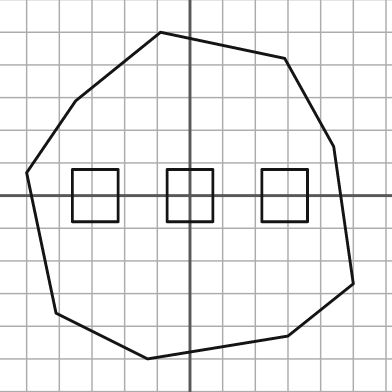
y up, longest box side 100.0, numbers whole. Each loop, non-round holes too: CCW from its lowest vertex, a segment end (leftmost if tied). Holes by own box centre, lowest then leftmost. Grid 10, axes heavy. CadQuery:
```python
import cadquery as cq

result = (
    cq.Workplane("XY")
    .moveTo(-13.0, -50.0)
    .lineTo(30.0, -43.0)
    .lineTo(50.0, -27.0)
    .lineTo(44.0, 15.0)
    .lineTo(29.0, 42.0)
    .lineTo(-9.0, 50.0)
    .lineTo(-35.0, 29.0)
    .lineTo(-50.0, 7.0)
    .lineTo(-41.0, -36.0)
    .close()
    .moveTo(-36.0, -8.0)
    .lineTo(-22.0, -8.0)
    .lineTo(-22.0, 8.0)
    .lineTo(-36.0, 8.0)
    .close()
    .moveTo(-7.0, -8.0)
    .lineTo(7.0, -8.0)
    .lineTo(7.0, 8.0)
    .lineTo(-7.0, 8.0)
    .close()
    .moveTo(22.0, -8.0)
    .lineTo(36.0, -8.0)
    .lineTo(36.0, 8.0)
    .lineTo(22.0, 8.0)
    .close()
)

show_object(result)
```